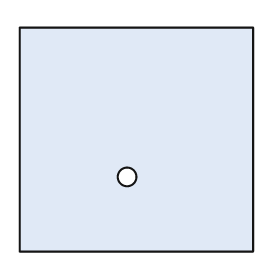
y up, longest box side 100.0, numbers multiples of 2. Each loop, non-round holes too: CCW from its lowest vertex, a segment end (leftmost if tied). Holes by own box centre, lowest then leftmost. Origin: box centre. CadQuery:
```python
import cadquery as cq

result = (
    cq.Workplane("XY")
    .moveTo(-50.0, -48.0)
    .lineTo(50.0, -48.0)
    .lineTo(50.0, 48.0)
    .lineTo(-50.0, 48.0)
    .close()
    .moveTo(-4.0, -16.0)
    .circle(4.0)
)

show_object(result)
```